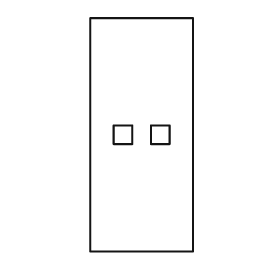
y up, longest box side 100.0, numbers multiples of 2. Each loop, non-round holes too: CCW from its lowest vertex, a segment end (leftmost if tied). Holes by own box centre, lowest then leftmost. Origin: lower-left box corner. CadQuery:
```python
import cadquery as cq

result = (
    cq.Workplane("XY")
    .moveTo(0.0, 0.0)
    .lineTo(44.0, 0.0)
    .lineTo(44.0, 100.0)
    .lineTo(0.0, 100.0)
    .close()
    .moveTo(10.0, 46.0)
    .lineTo(18.0, 46.0)
    .lineTo(18.0, 54.0)
    .lineTo(10.0, 54.0)
    .close()
    .moveTo(26.0, 46.0)
    .lineTo(34.0, 46.0)
    .lineTo(34.0, 54.0)
    .lineTo(26.0, 54.0)
    .close()
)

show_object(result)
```